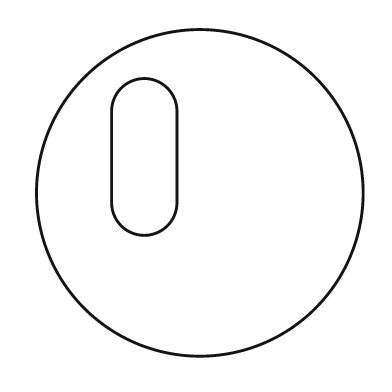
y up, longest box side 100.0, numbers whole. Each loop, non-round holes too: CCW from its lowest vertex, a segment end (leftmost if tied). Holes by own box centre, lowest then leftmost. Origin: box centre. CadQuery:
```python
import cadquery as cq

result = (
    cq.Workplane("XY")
    .moveTo(0.0, 0.0)
    .circle(50.0)
    .moveTo(-27.0, -3.0)
    .threePointArc((-17.0, -13.0), (-7.0, -3.0))
    .lineTo(-7.0, 25.0)
    .threePointArc((-17.0, 35.0), (-27.0, 25.0))
    .close()
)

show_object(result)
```